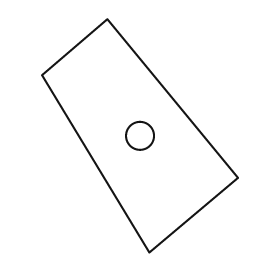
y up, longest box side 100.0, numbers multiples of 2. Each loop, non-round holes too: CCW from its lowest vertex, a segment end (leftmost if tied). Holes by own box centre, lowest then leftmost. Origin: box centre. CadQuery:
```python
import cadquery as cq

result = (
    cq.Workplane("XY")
    .moveTo(4.0, -50.0)
    .lineTo(42.0, -18.0)
    .lineTo(-14.0, 50.0)
    .lineTo(-42.0, 26.0)
    .close()
    .moveTo(0.0, 0.0)
    .circle(6.0)
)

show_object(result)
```